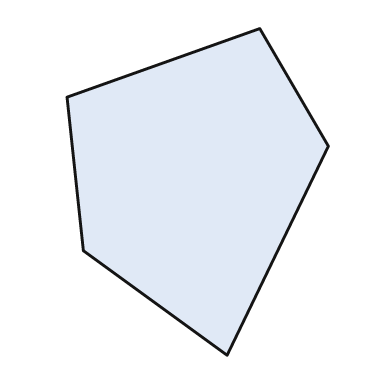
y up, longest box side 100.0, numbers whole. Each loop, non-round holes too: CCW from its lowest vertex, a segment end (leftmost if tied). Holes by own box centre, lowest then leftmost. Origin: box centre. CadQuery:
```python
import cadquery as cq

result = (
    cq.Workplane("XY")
    .moveTo(9.0, -50.0)
    .lineTo(40.0, 14.0)
    .lineTo(19.0, 50.0)
    .lineTo(-40.0, 29.0)
    .lineTo(-35.0, -18.0)
    .close()
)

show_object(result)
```